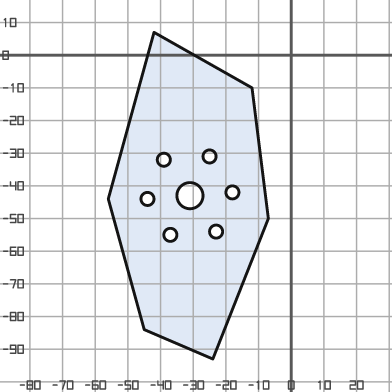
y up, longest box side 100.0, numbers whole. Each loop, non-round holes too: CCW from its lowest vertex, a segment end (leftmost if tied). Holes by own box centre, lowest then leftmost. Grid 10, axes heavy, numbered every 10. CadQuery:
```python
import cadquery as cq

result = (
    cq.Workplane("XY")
    .moveTo(-24.0, -93.0)
    .lineTo(-7.0, -50.0)
    .lineTo(-12.0, -10.0)
    .lineTo(-42.0, 7.0)
    .lineTo(-56.0, -44.0)
    .lineTo(-45.0, -84.0)
    .close()
    .moveTo(-37.0, -55.0)
    .circle(2.0)
    .moveTo(-23.0, -54.0)
    .circle(2.0)
    .moveTo(-44.0, -44.0)
    .circle(2.0)
    .moveTo(-31.0, -43.0)
    .circle(4.0)
    .moveTo(-18.0, -42.0)
    .circle(2.0)
    .moveTo(-39.0, -32.0)
    .circle(2.0)
    .moveTo(-25.0, -31.0)
    .circle(2.0)
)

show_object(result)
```